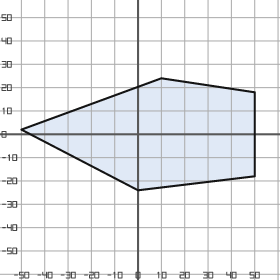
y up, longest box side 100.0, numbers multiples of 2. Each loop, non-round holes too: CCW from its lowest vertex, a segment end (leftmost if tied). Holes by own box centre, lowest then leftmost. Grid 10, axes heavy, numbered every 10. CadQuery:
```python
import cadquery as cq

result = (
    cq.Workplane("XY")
    .moveTo(0.0, -24.0)
    .lineTo(50.0, -18.0)
    .lineTo(50.0, 18.0)
    .lineTo(10.0, 24.0)
    .lineTo(-50.0, 2.0)
    .close()
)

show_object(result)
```